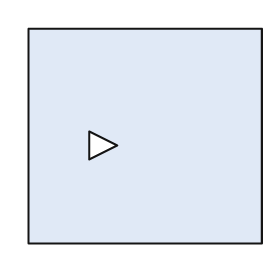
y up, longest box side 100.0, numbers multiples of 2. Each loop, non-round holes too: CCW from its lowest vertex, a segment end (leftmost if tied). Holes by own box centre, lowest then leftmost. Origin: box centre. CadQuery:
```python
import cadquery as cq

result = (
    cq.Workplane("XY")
    .moveTo(-50.0, -46.0)
    .lineTo(50.0, -46.0)
    .lineTo(50.0, 46.0)
    .lineTo(-50.0, 46.0)
    .close()
    .moveTo(-24.0, -10.0)
    .lineTo(-12.0, -4.0)
    .lineTo(-24.0, 2.0)
    .close()
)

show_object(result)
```